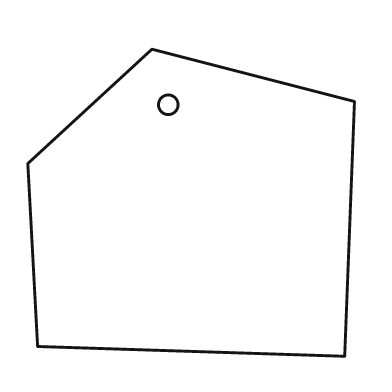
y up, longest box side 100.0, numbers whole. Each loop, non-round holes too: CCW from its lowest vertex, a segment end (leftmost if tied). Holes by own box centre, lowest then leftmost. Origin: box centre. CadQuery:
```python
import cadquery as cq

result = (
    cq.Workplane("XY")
    .moveTo(47.0, -47.0)
    .lineTo(50.0, 31.0)
    .lineTo(-12.0, 47.0)
    .lineTo(-50.0, 12.0)
    .lineTo(-47.0, -44.0)
    .close()
    .moveTo(-7.0, 30.0)
    .circle(3.0)
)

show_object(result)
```